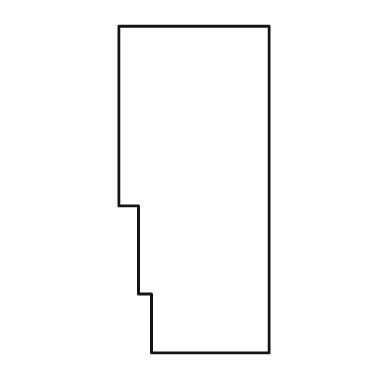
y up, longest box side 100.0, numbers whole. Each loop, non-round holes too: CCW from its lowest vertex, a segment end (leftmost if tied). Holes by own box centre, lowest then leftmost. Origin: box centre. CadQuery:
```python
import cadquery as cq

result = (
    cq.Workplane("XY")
    .moveTo(-13.0, -50.0)
    .lineTo(23.0, -50.0)
    .lineTo(23.0, 50.0)
    .lineTo(-23.0, 50.0)
    .lineTo(-23.0, -5.0)
    .lineTo(-17.0, -5.0)
    .lineTo(-17.0, -32.0)
    .lineTo(-13.0, -32.0)
    .close()
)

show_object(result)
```